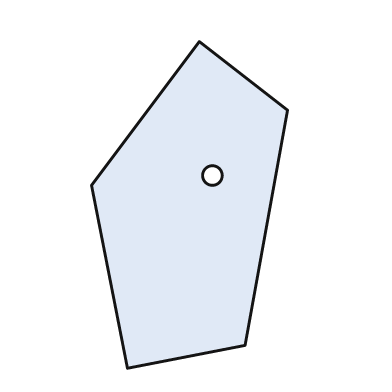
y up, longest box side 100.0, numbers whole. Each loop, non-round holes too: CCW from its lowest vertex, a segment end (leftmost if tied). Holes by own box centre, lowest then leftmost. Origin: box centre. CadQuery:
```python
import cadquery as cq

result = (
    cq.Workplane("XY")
    .moveTo(-19.0, -50.0)
    .lineTo(17.0, -43.0)
    .lineTo(30.0, 29.0)
    .lineTo(3.0, 50.0)
    .lineTo(-30.0, 6.0)
    .close()
    .moveTo(7.0, 9.0)
    .circle(3.0)
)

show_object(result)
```